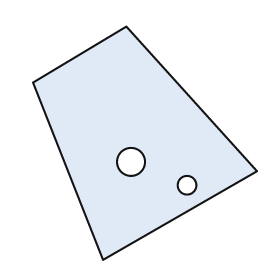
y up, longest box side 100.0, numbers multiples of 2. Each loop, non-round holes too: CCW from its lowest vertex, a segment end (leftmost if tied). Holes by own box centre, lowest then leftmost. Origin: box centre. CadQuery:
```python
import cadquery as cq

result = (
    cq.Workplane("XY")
    .moveTo(-18.0, -50.0)
    .lineTo(48.0, -12.0)
    .lineTo(-8.0, 50.0)
    .lineTo(-48.0, 26.0)
    .close()
    .moveTo(18.0, -18.0)
    .circle(4.0)
    .moveTo(-6.0, -8.0)
    .circle(6.0)
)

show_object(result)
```